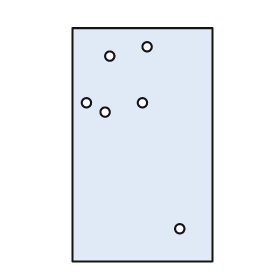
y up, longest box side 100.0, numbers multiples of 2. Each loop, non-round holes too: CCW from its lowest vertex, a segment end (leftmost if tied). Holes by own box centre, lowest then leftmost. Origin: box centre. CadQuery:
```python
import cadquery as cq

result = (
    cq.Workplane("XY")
    .moveTo(-30.0, -50.0)
    .lineTo(30.0, -50.0)
    .lineTo(30.0, 50.0)
    .lineTo(-30.0, 50.0)
    .close()
    .moveTo(16.0, -36.0)
    .circle(2.0)
    .moveTo(-16.0, 14.0)
    .circle(2.0)
    .moveTo(-24.0, 18.0)
    .circle(2.0)
    .moveTo(0.0, 18.0)
    .circle(2.0)
    .moveTo(-14.0, 38.0)
    .circle(2.0)
    .moveTo(2.0, 42.0)
    .circle(2.0)
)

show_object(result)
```